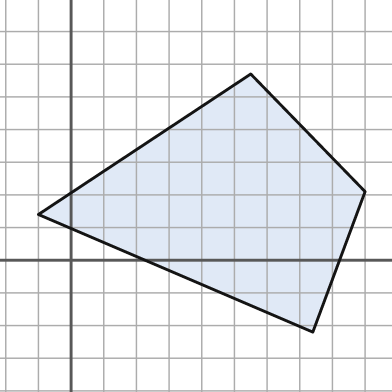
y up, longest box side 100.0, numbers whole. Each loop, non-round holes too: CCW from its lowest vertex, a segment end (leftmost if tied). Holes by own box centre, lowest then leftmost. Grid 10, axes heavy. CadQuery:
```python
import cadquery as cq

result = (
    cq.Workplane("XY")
    .moveTo(74.0, -22.0)
    .lineTo(90.0, 21.0)
    .lineTo(55.0, 57.0)
    .lineTo(-10.0, 14.0)
    .close()
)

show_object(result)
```